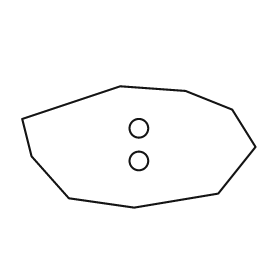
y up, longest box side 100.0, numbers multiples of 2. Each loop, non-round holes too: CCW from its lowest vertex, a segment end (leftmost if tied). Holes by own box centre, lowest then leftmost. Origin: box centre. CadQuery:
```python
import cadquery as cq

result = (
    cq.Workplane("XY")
    .moveTo(-2.0, -26.0)
    .lineTo(34.0, -20.0)
    .lineTo(50.0, 0.0)
    .lineTo(40.0, 16.0)
    .lineTo(20.0, 24.0)
    .lineTo(-8.0, 26.0)
    .lineTo(-50.0, 12.0)
    .lineTo(-46.0, -4.0)
    .lineTo(-30.0, -22.0)
    .close()
    .moveTo(0.0, -6.0)
    .circle(4.0)
    .moveTo(0.0, 8.0)
    .circle(4.0)
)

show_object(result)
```